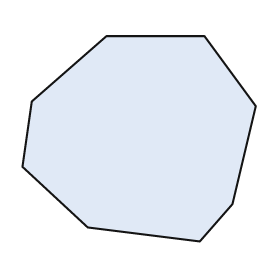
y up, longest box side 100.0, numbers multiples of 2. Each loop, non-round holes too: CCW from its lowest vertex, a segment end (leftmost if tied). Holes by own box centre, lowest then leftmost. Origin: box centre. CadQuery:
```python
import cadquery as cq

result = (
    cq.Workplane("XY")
    .moveTo(26.0, -44.0)
    .lineTo(40.0, -28.0)
    .lineTo(50.0, 14.0)
    .lineTo(28.0, 44.0)
    .lineTo(-14.0, 44.0)
    .lineTo(-46.0, 16.0)
    .lineTo(-50.0, -12.0)
    .lineTo(-22.0, -38.0)
    .close()
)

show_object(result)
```